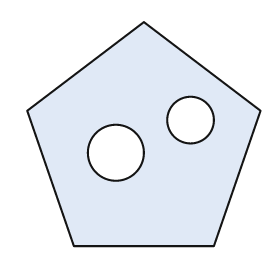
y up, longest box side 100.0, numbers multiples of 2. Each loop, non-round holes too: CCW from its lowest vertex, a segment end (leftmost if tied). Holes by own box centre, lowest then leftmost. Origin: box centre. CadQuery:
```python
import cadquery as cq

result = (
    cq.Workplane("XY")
    .moveTo(-30.0, -48.0)
    .lineTo(30.0, -48.0)
    .lineTo(50.0, 10.0)
    .lineTo(0.0, 48.0)
    .lineTo(-50.0, 10.0)
    .close()
    .moveTo(-12.0, -8.0)
    .circle(12.0)
    .moveTo(20.0, 6.0)
    .circle(10.0)
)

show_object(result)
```